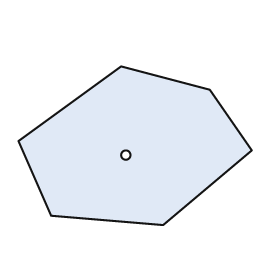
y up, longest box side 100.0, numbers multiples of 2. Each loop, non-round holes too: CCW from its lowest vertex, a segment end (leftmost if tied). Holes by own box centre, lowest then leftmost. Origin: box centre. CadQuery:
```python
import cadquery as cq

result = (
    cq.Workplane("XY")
    .moveTo(12.0, -34.0)
    .lineTo(50.0, -2.0)
    .lineTo(32.0, 24.0)
    .lineTo(-6.0, 34.0)
    .lineTo(-50.0, 2.0)
    .lineTo(-36.0, -30.0)
    .close()
    .moveTo(-4.0, -4.0)
    .circle(2.0)
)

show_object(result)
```